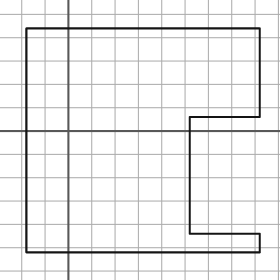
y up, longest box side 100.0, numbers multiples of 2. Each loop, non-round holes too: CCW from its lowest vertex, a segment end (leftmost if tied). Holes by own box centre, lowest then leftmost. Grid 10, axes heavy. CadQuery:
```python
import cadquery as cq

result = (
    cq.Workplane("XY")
    .moveTo(-18.0, -52.0)
    .lineTo(82.0, -52.0)
    .lineTo(82.0, -44.0)
    .lineTo(52.0, -44.0)
    .lineTo(52.0, 6.0)
    .lineTo(82.0, 6.0)
    .lineTo(82.0, 44.0)
    .lineTo(-18.0, 44.0)
    .close()
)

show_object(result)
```